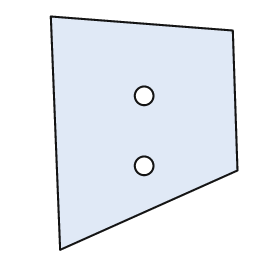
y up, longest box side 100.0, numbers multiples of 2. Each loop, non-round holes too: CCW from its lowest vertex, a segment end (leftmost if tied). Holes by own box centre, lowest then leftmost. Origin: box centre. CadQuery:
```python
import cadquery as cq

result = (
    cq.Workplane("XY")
    .moveTo(-36.0, -50.0)
    .lineTo(40.0, -16.0)
    .lineTo(38.0, 44.0)
    .lineTo(-40.0, 50.0)
    .close()
    .moveTo(0.0, -14.0)
    .circle(4.0)
    .moveTo(0.0, 16.0)
    .circle(4.0)
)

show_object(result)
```